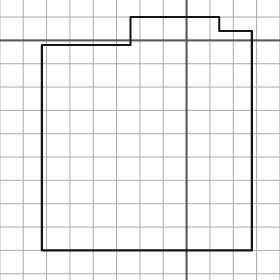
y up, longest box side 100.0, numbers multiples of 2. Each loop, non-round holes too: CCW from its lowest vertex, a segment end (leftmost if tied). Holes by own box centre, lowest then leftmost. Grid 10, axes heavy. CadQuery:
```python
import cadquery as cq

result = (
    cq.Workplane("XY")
    .moveTo(-62.0, -90.0)
    .lineTo(28.0, -90.0)
    .lineTo(28.0, 4.0)
    .lineTo(14.0, 4.0)
    .lineTo(14.0, 10.0)
    .lineTo(-24.0, 10.0)
    .lineTo(-24.0, -2.0)
    .lineTo(-62.0, -2.0)
    .close()
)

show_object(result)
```